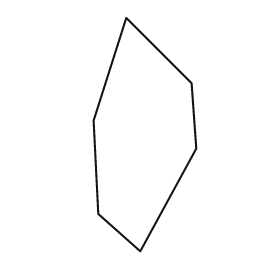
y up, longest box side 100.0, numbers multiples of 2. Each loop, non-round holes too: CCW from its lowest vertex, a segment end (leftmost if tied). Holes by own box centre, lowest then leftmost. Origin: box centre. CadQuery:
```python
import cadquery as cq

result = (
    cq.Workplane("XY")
    .moveTo(-2.0, -50.0)
    .lineTo(22.0, -6.0)
    .lineTo(20.0, 22.0)
    .lineTo(-8.0, 50.0)
    .lineTo(-22.0, 6.0)
    .lineTo(-20.0, -34.0)
    .close()
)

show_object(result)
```